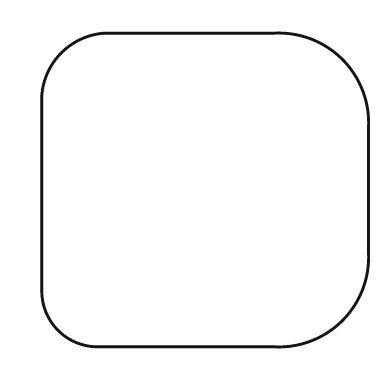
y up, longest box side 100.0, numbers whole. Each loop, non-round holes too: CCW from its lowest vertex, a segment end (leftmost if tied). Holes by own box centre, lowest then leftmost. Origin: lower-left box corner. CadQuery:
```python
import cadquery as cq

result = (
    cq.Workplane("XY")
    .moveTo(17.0, 0.0)
    .lineTo(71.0, 0.0)
    .threePointArc((92.0, 8.0), (100.0, 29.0))
    .lineTo(100.0, 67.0)
    .threePointArc((92.0, 88.0), (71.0, 96.0))
    .lineTo(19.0, 96.0)
    .threePointArc((6.0, 90.0), (0.0, 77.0))
    .lineTo(0.0, 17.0)
    .threePointArc((5.0, 5.0), (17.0, 0.0))
    .close()
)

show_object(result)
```